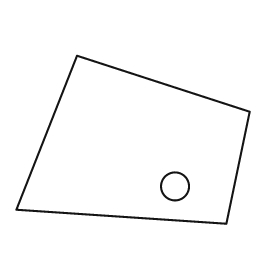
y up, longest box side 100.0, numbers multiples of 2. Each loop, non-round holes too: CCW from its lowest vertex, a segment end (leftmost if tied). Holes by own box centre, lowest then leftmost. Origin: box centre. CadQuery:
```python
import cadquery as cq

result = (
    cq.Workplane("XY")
    .moveTo(40.0, -36.0)
    .lineTo(50.0, 12.0)
    .lineTo(-24.0, 36.0)
    .lineTo(-50.0, -30.0)
    .close()
    .moveTo(18.0, -20.0)
    .circle(6.0)
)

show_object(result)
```